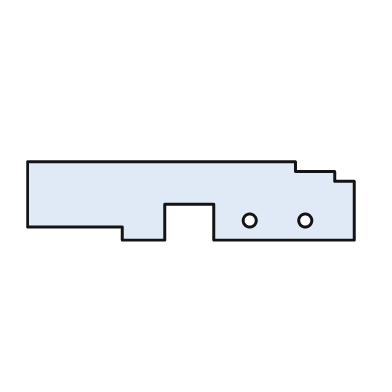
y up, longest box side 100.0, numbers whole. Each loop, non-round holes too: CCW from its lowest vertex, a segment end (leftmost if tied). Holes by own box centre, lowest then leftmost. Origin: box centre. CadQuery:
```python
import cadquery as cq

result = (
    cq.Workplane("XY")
    .moveTo(-21.0, -12.0)
    .lineTo(-8.0, -12.0)
    .lineTo(-8.0, -1.0)
    .lineTo(7.0, -1.0)
    .lineTo(7.0, -12.0)
    .lineTo(50.0, -12.0)
    .lineTo(50.0, 6.0)
    .lineTo(44.0, 6.0)
    .lineTo(44.0, 9.0)
    .lineTo(32.0, 9.0)
    .lineTo(32.0, 12.0)
    .lineTo(-50.0, 12.0)
    .lineTo(-50.0, -8.0)
    .lineTo(-21.0, -8.0)
    .close()
    .moveTo(18.0, -6.0)
    .circle(2.0)
    .moveTo(35.0, -6.0)
    .circle(2.0)
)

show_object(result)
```